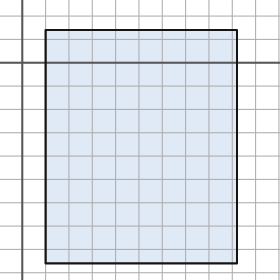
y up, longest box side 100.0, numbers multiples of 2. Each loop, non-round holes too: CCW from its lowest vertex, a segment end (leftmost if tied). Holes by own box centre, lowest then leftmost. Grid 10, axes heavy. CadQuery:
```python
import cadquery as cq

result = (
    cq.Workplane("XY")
    .moveTo(10.0, -86.0)
    .lineTo(92.0, -86.0)
    .lineTo(92.0, 14.0)
    .lineTo(10.0, 14.0)
    .close()
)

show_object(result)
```